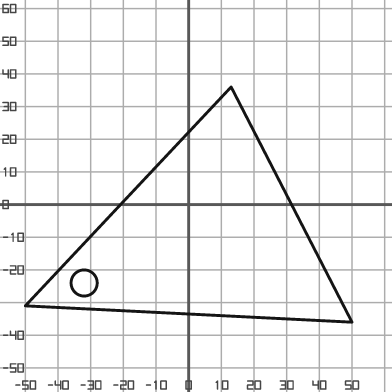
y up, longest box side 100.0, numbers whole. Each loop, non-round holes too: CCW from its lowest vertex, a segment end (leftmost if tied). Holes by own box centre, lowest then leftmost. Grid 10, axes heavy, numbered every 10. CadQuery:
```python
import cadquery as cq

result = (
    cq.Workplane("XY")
    .moveTo(50.0, -36.0)
    .lineTo(13.0, 36.0)
    .lineTo(-50.0, -31.0)
    .close()
    .moveTo(-32.0, -24.0)
    .circle(4.0)
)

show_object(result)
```